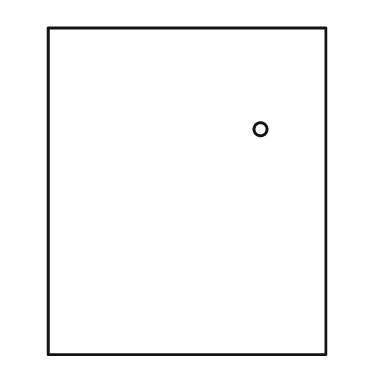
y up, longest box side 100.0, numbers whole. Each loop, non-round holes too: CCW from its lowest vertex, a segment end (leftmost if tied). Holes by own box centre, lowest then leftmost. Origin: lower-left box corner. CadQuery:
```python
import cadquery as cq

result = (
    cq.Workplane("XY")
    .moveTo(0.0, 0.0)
    .lineTo(85.0, 0.0)
    .lineTo(85.0, 100.0)
    .lineTo(0.0, 100.0)
    .close()
    .moveTo(65.0, 69.0)
    .circle(2.0)
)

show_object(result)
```